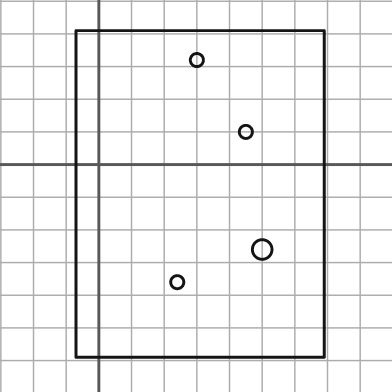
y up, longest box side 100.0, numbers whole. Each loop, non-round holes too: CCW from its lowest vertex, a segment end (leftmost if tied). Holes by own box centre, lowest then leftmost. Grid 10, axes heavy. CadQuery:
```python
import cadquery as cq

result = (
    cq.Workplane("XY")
    .moveTo(-7.0, -59.0)
    .lineTo(69.0, -59.0)
    .lineTo(69.0, 41.0)
    .lineTo(-7.0, 41.0)
    .close()
    .moveTo(24.0, -36.0)
    .circle(2.0)
    .moveTo(50.0, -26.0)
    .circle(3.0)
    .moveTo(45.0, 10.0)
    .circle(2.0)
    .moveTo(30.0, 32.0)
    .circle(2.0)
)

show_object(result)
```